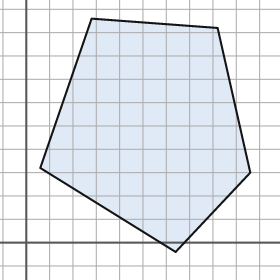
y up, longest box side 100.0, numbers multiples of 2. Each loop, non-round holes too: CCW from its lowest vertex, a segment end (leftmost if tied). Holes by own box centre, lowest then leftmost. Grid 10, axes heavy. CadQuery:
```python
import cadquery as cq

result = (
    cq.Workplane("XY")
    .moveTo(64.0, -4.0)
    .lineTo(96.0, 30.0)
    .lineTo(82.0, 92.0)
    .lineTo(28.0, 96.0)
    .lineTo(6.0, 32.0)
    .close()
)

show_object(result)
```